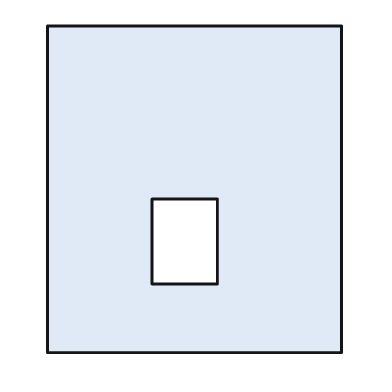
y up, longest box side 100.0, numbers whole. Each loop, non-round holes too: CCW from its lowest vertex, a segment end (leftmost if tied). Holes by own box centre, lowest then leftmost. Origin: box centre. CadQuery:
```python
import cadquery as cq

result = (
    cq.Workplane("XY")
    .moveTo(-45.0, -50.0)
    .lineTo(45.0, -50.0)
    .lineTo(45.0, 50.0)
    .lineTo(-45.0, 50.0)
    .close()
    .moveTo(-13.0, -29.0)
    .lineTo(7.0, -29.0)
    .lineTo(7.0, -3.0)
    .lineTo(-13.0, -3.0)
    .close()
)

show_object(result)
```